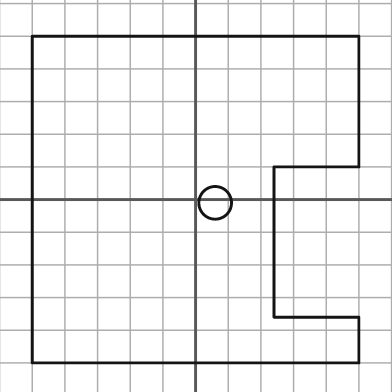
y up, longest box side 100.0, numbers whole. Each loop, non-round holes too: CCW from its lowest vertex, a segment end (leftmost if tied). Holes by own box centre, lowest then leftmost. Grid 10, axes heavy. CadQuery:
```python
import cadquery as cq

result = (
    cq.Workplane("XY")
    .moveTo(-50.0, -50.0)
    .lineTo(50.0, -50.0)
    .lineTo(50.0, -36.0)
    .lineTo(24.0, -36.0)
    .lineTo(24.0, 10.0)
    .lineTo(50.0, 10.0)
    .lineTo(50.0, 50.0)
    .lineTo(-50.0, 50.0)
    .close()
    .moveTo(6.0, -1.0)
    .circle(5.0)
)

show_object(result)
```